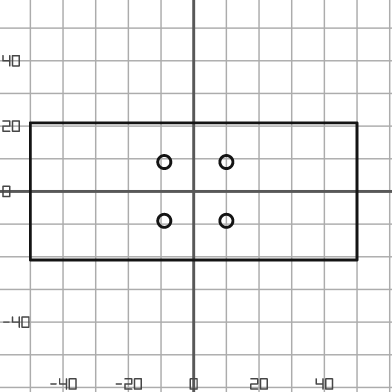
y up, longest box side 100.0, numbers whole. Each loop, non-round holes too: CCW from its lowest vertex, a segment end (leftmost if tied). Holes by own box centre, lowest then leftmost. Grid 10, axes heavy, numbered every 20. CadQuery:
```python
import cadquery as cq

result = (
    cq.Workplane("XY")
    .moveTo(-50.0, -21.0)
    .lineTo(50.0, -21.0)
    .lineTo(50.0, 21.0)
    .lineTo(-50.0, 21.0)
    .close()
    .moveTo(-9.0, -9.0)
    .circle(2.0)
    .moveTo(10.0, -9.0)
    .circle(2.0)
    .moveTo(-9.0, 9.0)
    .circle(2.0)
    .moveTo(10.0, 9.0)
    .circle(2.0)
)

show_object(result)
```